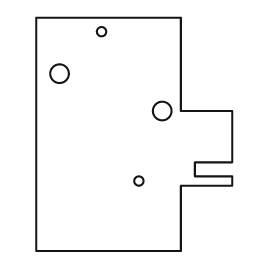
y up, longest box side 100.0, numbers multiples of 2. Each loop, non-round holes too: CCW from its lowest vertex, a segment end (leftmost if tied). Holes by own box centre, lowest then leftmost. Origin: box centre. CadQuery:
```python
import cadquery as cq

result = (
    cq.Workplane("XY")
    .moveTo(-42.0, -50.0)
    .lineTo(20.0, -50.0)
    .lineTo(20.0, -22.0)
    .lineTo(42.0, -22.0)
    .lineTo(42.0, -18.0)
    .lineTo(26.0, -18.0)
    .lineTo(26.0, -12.0)
    .lineTo(42.0, -12.0)
    .lineTo(42.0, 10.0)
    .lineTo(20.0, 10.0)
    .lineTo(20.0, 50.0)
    .lineTo(-42.0, 50.0)
    .close()
    .moveTo(2.0, -20.0)
    .circle(2.0)
    .moveTo(12.0, 10.0)
    .circle(4.0)
    .moveTo(-32.0, 26.0)
    .circle(4.0)
    .moveTo(-14.0, 44.0)
    .circle(2.0)
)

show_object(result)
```